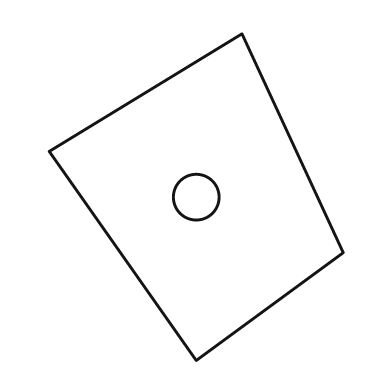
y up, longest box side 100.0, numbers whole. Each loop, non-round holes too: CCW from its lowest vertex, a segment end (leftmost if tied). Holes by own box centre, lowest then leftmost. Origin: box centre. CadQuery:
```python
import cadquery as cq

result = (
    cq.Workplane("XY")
    .moveTo(0.0, -50.0)
    .lineTo(45.0, -17.0)
    .lineTo(14.0, 50.0)
    .lineTo(-45.0, 14.0)
    .close()
    .moveTo(0.0, 0.0)
    .circle(7.0)
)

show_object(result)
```